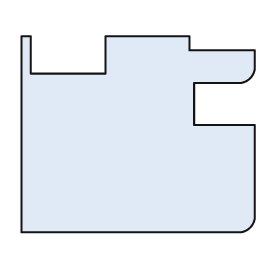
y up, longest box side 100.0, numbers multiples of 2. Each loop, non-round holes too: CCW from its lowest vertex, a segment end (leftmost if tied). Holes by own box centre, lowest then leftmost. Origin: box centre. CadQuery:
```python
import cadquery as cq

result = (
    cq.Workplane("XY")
    .moveTo(-50.0, -42.0)
    .lineTo(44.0, -42.0)
    .threePointArc((48.0, -40.0), (50.0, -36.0))
    .lineTo(50.0, 4.0)
    .lineTo(24.0, 4.0)
    .lineTo(24.0, 22.0)
    .lineTo(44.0, 22.0)
    .threePointArc((48.0, 24.0), (50.0, 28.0))
    .lineTo(50.0, 36.0)
    .lineTo(22.0, 36.0)
    .lineTo(22.0, 42.0)
    .lineTo(-14.0, 42.0)
    .lineTo(-14.0, 26.0)
    .lineTo(-46.0, 26.0)
    .lineTo(-46.0, 42.0)
    .lineTo(-50.0, 42.0)
    .close()
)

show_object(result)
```